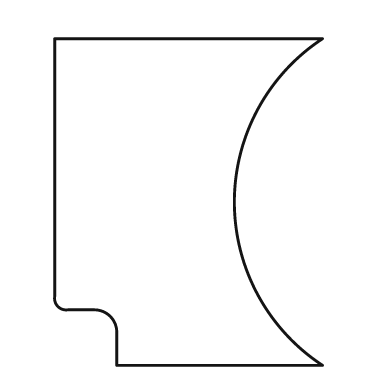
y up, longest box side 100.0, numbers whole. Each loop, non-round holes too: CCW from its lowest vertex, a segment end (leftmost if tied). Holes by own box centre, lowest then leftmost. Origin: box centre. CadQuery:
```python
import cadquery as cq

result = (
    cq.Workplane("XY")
    .moveTo(-22.0, -50.0)
    .lineTo(41.0, -50.0)
    .threePointArc((14.0, 0.0), (41.0, 50.0))
    .lineTo(-41.0, 50.0)
    .lineTo(-41.0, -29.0)
    .threePointArc((-40.0, -32.0), (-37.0, -33.0))
    .lineTo(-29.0, -33.0)
    .threePointArc((-24.0, -35.0), (-22.0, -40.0))
    .close()
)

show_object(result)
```